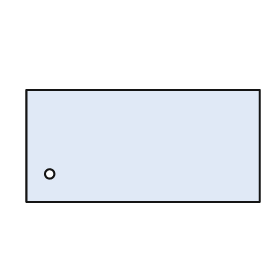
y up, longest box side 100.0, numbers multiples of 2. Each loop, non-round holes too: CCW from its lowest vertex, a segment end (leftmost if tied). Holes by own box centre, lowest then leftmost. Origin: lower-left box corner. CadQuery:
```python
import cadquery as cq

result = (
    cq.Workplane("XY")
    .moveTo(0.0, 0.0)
    .lineTo(100.0, 0.0)
    .lineTo(100.0, 48.0)
    .lineTo(0.0, 48.0)
    .close()
    .moveTo(10.0, 12.0)
    .circle(2.0)
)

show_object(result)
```